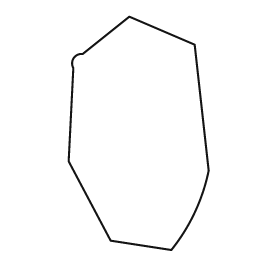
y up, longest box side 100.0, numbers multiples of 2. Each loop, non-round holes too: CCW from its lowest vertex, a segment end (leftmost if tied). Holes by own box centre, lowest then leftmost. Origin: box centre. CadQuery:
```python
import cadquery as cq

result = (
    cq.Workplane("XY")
    .moveTo(14.0, -50.0)
    .threePointArc((24.0, -34.0), (30.0, -16.0))
    .lineTo(24.0, 38.0)
    .lineTo(-4.0, 50.0)
    .lineTo(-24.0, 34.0)
    .threePointArc((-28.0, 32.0), (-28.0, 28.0))
    .lineTo(-30.0, -12.0)
    .lineTo(-12.0, -46.0)
    .close()
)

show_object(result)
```